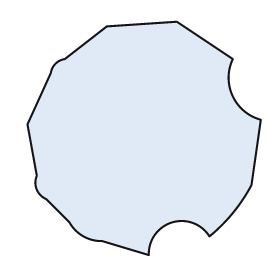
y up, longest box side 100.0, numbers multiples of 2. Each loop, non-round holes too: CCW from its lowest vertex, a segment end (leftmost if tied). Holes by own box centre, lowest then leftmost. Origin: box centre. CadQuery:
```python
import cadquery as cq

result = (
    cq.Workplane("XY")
    .moveTo(2.0, -50.0)
    .threePointArc((12.0, -36.0), (28.0, -42.0))
    .threePointArc((38.0, -32.0), (46.0, -20.0))
    .lineTo(50.0, 8.0)
    .threePointArc((38.0, 18.0), (38.0, 34.0))
    .lineTo(14.0, 50.0)
    .lineTo(-16.0, 48.0)
    .lineTo(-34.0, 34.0)
    .threePointArc((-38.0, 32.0), (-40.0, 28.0))
    .lineTo(-50.0, 6.0)
    .lineTo(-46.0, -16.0)
    .threePointArc((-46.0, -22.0), (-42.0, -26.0))
    .lineTo(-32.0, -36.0)
    .threePointArc((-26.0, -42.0), (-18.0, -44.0))
    .close()
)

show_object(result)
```